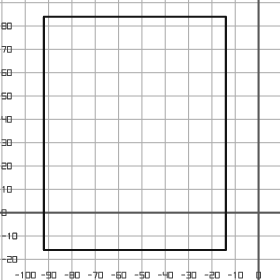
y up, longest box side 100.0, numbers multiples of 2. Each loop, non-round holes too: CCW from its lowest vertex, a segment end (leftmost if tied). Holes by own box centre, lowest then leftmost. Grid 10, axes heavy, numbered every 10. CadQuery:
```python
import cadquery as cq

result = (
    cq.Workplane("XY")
    .moveTo(-92.0, -16.0)
    .lineTo(-14.0, -16.0)
    .lineTo(-14.0, 84.0)
    .lineTo(-92.0, 84.0)
    .close()
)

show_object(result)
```